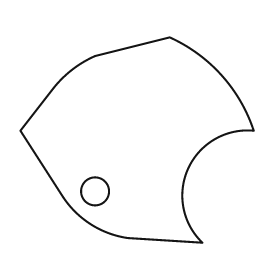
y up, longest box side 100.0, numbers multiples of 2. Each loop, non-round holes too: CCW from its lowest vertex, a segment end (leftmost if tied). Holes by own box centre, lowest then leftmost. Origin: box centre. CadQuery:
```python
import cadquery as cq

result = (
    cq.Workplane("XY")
    .moveTo(28.0, -44.0)
    .threePointArc((22.0, -12.0), (50.0, 4.0))
    .threePointArc((36.0, 28.0), (14.0, 44.0))
    .lineTo(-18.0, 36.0)
    .threePointArc((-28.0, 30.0), (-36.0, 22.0))
    .lineTo(-50.0, 4.0)
    .lineTo(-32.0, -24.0)
    .threePointArc((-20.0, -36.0), (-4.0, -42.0))
    .close()
    .moveTo(-18.0, -22.0)
    .circle(6.0)
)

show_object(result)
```